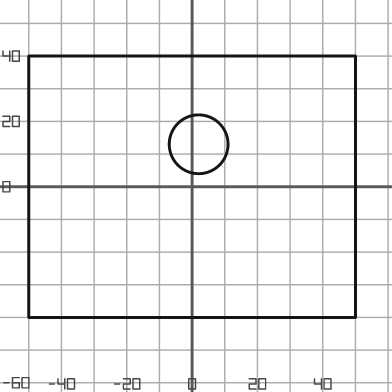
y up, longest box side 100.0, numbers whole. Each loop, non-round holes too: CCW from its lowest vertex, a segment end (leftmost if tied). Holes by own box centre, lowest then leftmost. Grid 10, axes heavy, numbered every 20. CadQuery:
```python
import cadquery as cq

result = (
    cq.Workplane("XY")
    .moveTo(-50.0, -40.0)
    .lineTo(50.0, -40.0)
    .lineTo(50.0, 40.0)
    .lineTo(-50.0, 40.0)
    .close()
    .moveTo(2.0, 13.0)
    .circle(9.0)
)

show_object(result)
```